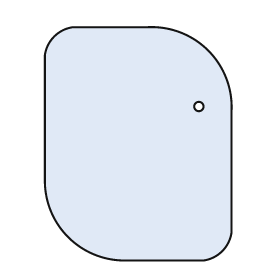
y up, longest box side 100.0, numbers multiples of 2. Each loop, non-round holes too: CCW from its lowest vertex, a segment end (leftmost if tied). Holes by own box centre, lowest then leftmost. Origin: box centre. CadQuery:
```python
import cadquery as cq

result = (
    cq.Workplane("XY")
    .moveTo(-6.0, -50.0)
    .lineTo(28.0, -50.0)
    .threePointArc((36.0, -46.0), (40.0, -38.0))
    .lineTo(40.0, 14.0)
    .threePointArc((30.0, 40.0), (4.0, 50.0))
    .lineTo(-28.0, 50.0)
    .threePointArc((-36.0, 46.0), (-40.0, 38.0))
    .lineTo(-40.0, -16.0)
    .threePointArc((-30.0, -40.0), (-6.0, -50.0))
    .close()
    .moveTo(26.0, 16.0)
    .circle(2.0)
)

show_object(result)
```